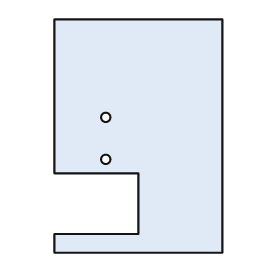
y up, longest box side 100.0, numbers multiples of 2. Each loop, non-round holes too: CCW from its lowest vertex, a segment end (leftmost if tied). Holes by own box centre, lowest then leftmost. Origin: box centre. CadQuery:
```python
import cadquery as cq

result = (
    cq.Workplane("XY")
    .moveTo(-36.0, -50.0)
    .lineTo(36.0, -50.0)
    .lineTo(36.0, 50.0)
    .lineTo(-36.0, 50.0)
    .lineTo(-36.0, -16.0)
    .lineTo(0.0, -16.0)
    .lineTo(0.0, -42.0)
    .lineTo(-36.0, -42.0)
    .close()
    .moveTo(-14.0, -10.0)
    .circle(2.0)
    .moveTo(-14.0, 8.0)
    .circle(2.0)
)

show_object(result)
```